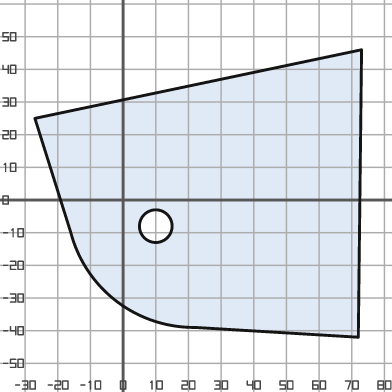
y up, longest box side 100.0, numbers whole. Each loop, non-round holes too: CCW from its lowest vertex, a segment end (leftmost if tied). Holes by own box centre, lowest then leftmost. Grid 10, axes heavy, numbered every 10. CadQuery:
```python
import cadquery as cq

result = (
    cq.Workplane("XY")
    .moveTo(72.0, -42.0)
    .lineTo(73.0, 46.0)
    .lineTo(-27.0, 25.0)
    .lineTo(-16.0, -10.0)
    .threePointArc((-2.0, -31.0), (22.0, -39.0))
    .close()
    .moveTo(10.0, -8.0)
    .circle(5.0)
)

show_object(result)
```